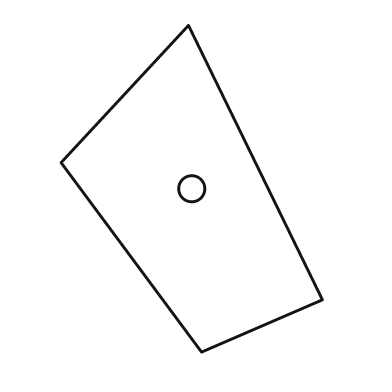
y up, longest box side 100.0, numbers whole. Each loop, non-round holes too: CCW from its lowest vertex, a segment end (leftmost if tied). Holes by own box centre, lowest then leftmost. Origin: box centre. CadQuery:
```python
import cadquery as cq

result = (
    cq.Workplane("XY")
    .moveTo(3.0, -50.0)
    .lineTo(40.0, -34.0)
    .lineTo(-1.0, 50.0)
    .lineTo(-40.0, 8.0)
    .close()
    .moveTo(0.0, 0.0)
    .circle(4.0)
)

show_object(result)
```